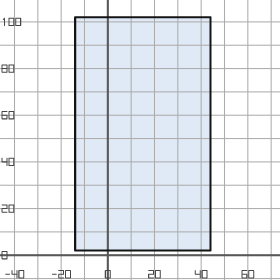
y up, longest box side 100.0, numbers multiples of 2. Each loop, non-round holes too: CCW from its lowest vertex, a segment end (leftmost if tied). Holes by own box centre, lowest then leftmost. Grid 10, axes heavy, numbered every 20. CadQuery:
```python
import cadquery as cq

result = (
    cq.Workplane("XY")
    .moveTo(-14.0, 2.0)
    .lineTo(44.0, 2.0)
    .lineTo(44.0, 102.0)
    .lineTo(-14.0, 102.0)
    .close()
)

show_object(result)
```